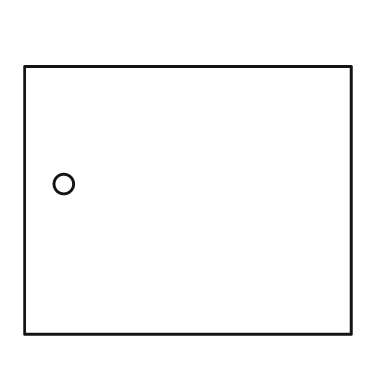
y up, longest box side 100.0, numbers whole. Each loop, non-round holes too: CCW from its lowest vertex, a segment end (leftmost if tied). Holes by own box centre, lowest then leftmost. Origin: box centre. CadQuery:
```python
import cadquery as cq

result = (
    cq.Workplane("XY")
    .moveTo(-50.0, -41.0)
    .lineTo(50.0, -41.0)
    .lineTo(50.0, 41.0)
    .lineTo(-50.0, 41.0)
    .close()
    .moveTo(-38.0, 5.0)
    .circle(3.0)
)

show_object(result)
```